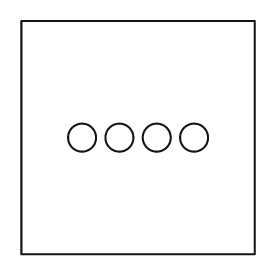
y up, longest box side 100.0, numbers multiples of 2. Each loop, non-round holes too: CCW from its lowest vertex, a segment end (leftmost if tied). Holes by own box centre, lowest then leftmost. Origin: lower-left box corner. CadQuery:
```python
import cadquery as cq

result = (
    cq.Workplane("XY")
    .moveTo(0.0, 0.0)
    .lineTo(100.0, 0.0)
    .lineTo(100.0, 100.0)
    .lineTo(0.0, 100.0)
    .close()
    .moveTo(26.0, 50.0)
    .circle(6.0)
    .moveTo(42.0, 50.0)
    .circle(6.0)
    .moveTo(58.0, 50.0)
    .circle(6.0)
    .moveTo(74.0, 50.0)
    .circle(6.0)
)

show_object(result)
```